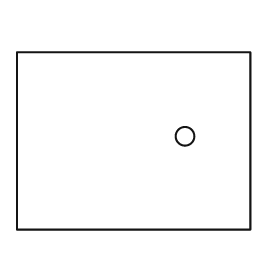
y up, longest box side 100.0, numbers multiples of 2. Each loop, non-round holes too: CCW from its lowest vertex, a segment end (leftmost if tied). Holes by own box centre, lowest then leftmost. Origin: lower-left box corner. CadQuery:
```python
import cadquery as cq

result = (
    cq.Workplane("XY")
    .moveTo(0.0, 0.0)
    .lineTo(100.0, 0.0)
    .lineTo(100.0, 76.0)
    .lineTo(0.0, 76.0)
    .close()
    .moveTo(72.0, 40.0)
    .circle(4.0)
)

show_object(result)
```